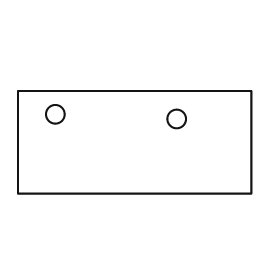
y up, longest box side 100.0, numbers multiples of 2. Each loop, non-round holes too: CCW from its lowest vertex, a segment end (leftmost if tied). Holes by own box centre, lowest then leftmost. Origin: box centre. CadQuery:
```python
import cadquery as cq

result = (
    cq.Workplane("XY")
    .moveTo(-50.0, -22.0)
    .lineTo(50.0, -22.0)
    .lineTo(50.0, 22.0)
    .lineTo(-50.0, 22.0)
    .close()
    .moveTo(18.0, 10.0)
    .circle(4.0)
    .moveTo(-34.0, 12.0)
    .circle(4.0)
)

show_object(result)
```